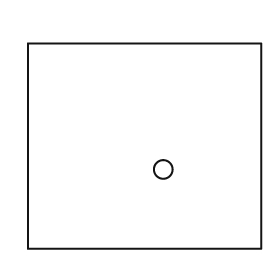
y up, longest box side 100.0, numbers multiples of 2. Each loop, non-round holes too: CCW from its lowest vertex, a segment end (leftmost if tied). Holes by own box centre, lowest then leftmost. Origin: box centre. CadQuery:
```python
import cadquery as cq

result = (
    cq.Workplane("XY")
    .moveTo(-50.0, -44.0)
    .lineTo(50.0, -44.0)
    .lineTo(50.0, 44.0)
    .lineTo(-50.0, 44.0)
    .close()
    .moveTo(8.0, -10.0)
    .circle(4.0)
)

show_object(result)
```